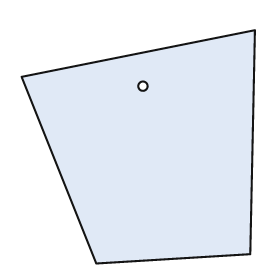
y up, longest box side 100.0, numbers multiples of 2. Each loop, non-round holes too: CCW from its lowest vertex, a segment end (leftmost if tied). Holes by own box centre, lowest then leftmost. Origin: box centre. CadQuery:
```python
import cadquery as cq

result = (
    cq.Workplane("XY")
    .moveTo(-18.0, -50.0)
    .lineTo(48.0, -46.0)
    .lineTo(50.0, 50.0)
    .lineTo(-50.0, 30.0)
    .close()
    .moveTo(2.0, 26.0)
    .circle(2.0)
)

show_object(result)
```